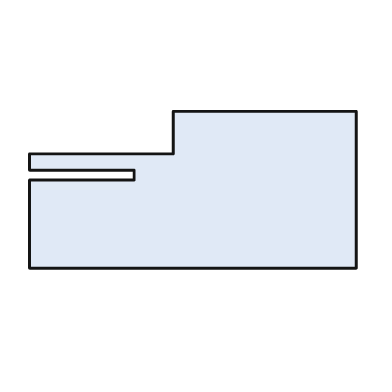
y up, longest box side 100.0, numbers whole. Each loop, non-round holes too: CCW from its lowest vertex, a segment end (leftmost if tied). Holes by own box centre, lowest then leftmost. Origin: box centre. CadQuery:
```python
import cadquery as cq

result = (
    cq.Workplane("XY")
    .moveTo(-50.0, -24.0)
    .lineTo(50.0, -24.0)
    .lineTo(50.0, 24.0)
    .lineTo(-6.0, 24.0)
    .lineTo(-6.0, 11.0)
    .lineTo(-50.0, 11.0)
    .lineTo(-50.0, 6.0)
    .lineTo(-18.0, 6.0)
    .lineTo(-18.0, 3.0)
    .lineTo(-50.0, 3.0)
    .close()
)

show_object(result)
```